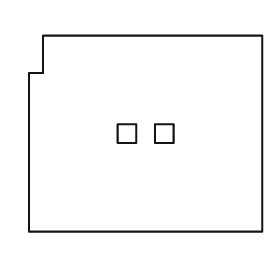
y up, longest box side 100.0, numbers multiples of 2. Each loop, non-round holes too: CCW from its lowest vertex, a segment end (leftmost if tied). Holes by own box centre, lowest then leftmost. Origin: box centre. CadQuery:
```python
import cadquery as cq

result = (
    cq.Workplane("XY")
    .moveTo(-50.0, -42.0)
    .lineTo(50.0, -42.0)
    .lineTo(50.0, 42.0)
    .lineTo(-44.0, 42.0)
    .lineTo(-44.0, 26.0)
    .lineTo(-50.0, 26.0)
    .close()
    .moveTo(-12.0, -4.0)
    .lineTo(-4.0, -4.0)
    .lineTo(-4.0, 4.0)
    .lineTo(-12.0, 4.0)
    .close()
    .moveTo(4.0, -4.0)
    .lineTo(12.0, -4.0)
    .lineTo(12.0, 4.0)
    .lineTo(4.0, 4.0)
    .close()
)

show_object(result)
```